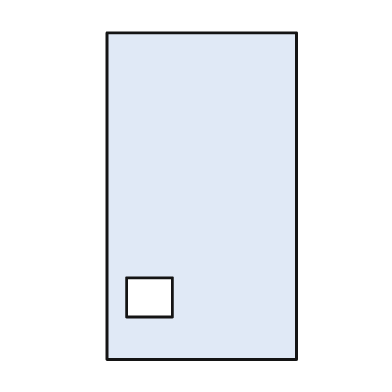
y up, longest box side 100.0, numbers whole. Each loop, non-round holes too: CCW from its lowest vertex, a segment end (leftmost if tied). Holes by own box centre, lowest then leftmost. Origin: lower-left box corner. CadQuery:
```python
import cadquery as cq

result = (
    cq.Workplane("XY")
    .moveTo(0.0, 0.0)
    .lineTo(58.0, 0.0)
    .lineTo(58.0, 100.0)
    .lineTo(0.0, 100.0)
    .close()
    .moveTo(6.0, 13.0)
    .lineTo(20.0, 13.0)
    .lineTo(20.0, 25.0)
    .lineTo(6.0, 25.0)
    .close()
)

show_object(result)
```